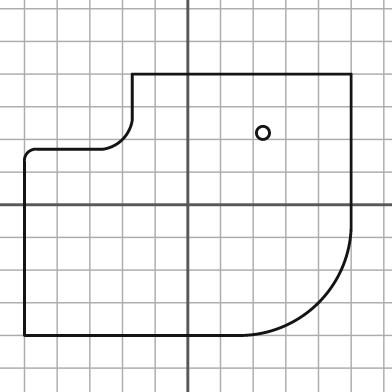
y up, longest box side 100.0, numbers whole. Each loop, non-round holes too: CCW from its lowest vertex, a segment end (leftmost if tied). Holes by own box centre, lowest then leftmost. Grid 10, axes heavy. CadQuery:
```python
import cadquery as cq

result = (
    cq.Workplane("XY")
    .moveTo(-50.0, -40.0)
    .lineTo(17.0, -40.0)
    .threePointArc((40.0, -30.0), (50.0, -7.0))
    .lineTo(50.0, 40.0)
    .lineTo(-17.0, 40.0)
    .lineTo(-17.0, 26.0)
    .threePointArc((-20.0, 20.0), (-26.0, 17.0))
    .lineTo(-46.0, 17.0)
    .threePointArc((-49.0, 16.0), (-50.0, 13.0))
    .close()
    .moveTo(23.0, 22.0)
    .circle(2.0)
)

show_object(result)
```